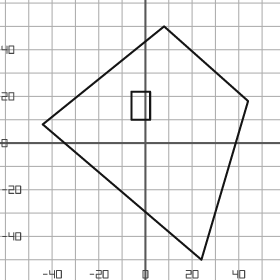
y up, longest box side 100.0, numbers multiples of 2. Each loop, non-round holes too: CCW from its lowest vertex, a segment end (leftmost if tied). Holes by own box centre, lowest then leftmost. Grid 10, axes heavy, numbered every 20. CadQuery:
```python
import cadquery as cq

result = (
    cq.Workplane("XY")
    .moveTo(24.0, -50.0)
    .lineTo(44.0, 18.0)
    .lineTo(8.0, 50.0)
    .lineTo(-44.0, 8.0)
    .close()
    .moveTo(-6.0, 10.0)
    .lineTo(2.0, 10.0)
    .lineTo(2.0, 22.0)
    .lineTo(-6.0, 22.0)
    .close()
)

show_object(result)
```